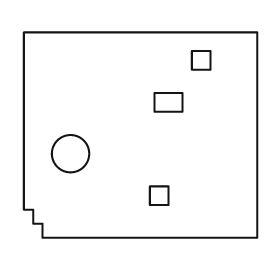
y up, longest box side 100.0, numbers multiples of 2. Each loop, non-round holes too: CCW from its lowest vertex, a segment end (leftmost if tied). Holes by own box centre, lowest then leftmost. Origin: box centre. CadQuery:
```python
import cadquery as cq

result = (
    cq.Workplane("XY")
    .moveTo(-42.0, -44.0)
    .lineTo(50.0, -44.0)
    .lineTo(50.0, 44.0)
    .lineTo(-50.0, 44.0)
    .lineTo(-50.0, -32.0)
    .lineTo(-46.0, -32.0)
    .lineTo(-46.0, -38.0)
    .lineTo(-42.0, -38.0)
    .close()
    .moveTo(4.0, -30.0)
    .lineTo(12.0, -30.0)
    .lineTo(12.0, -22.0)
    .lineTo(4.0, -22.0)
    .close()
    .moveTo(-30.0, -8.0)
    .circle(8.0)
    .moveTo(6.0, 10.0)
    .lineTo(18.0, 10.0)
    .lineTo(18.0, 18.0)
    .lineTo(6.0, 18.0)
    .close()
    .moveTo(22.0, 28.0)
    .lineTo(30.0, 28.0)
    .lineTo(30.0, 36.0)
    .lineTo(22.0, 36.0)
    .close()
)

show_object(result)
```